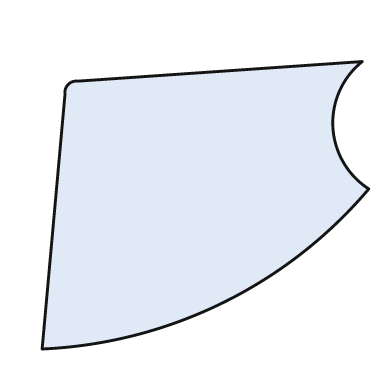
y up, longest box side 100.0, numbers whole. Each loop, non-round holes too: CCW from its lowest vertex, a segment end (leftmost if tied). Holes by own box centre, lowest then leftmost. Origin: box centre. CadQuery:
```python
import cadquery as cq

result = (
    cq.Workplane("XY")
    .moveTo(-50.0, -44.0)
    .threePointArc((5.0, -30.0), (50.0, 5.0))
    .threePointArc((39.0, 24.0), (48.0, 44.0))
    .lineTo(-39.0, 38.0)
    .threePointArc((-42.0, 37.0), (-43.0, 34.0))
    .close()
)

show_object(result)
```